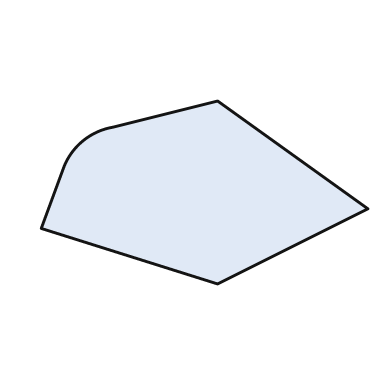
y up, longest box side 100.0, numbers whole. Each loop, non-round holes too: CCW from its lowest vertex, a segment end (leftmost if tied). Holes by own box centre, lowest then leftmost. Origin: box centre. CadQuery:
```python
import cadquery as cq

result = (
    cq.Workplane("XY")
    .moveTo(4.0, -28.0)
    .lineTo(50.0, -5.0)
    .lineTo(4.0, 28.0)
    .lineTo(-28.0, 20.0)
    .threePointArc((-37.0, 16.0), (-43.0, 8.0))
    .lineTo(-50.0, -11.0)
    .close()
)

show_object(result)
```